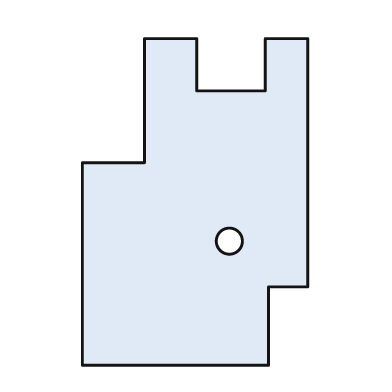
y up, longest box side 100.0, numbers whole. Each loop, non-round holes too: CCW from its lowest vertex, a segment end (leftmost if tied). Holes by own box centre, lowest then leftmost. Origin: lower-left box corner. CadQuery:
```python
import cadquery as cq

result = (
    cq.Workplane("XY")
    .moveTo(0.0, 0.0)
    .lineTo(57.0, 0.0)
    .lineTo(57.0, 24.0)
    .lineTo(69.0, 24.0)
    .lineTo(69.0, 100.0)
    .lineTo(56.0, 100.0)
    .lineTo(56.0, 84.0)
    .lineTo(35.0, 84.0)
    .lineTo(35.0, 100.0)
    .lineTo(19.0, 100.0)
    .lineTo(19.0, 62.0)
    .lineTo(0.0, 62.0)
    .close()
    .moveTo(45.0, 38.0)
    .circle(4.0)
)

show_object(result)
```